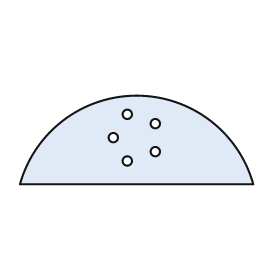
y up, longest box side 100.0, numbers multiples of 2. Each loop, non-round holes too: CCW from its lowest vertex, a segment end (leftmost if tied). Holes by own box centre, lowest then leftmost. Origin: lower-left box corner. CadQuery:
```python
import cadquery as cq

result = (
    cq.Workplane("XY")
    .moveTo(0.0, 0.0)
    .lineTo(100.0, 0.0)
    .threePointArc((50.0, 38.0), (0.0, 0.0))
    .close()
    .moveTo(46.0, 10.0)
    .circle(2.0)
    .moveTo(58.0, 14.0)
    .circle(2.0)
    .moveTo(40.0, 20.0)
    .circle(2.0)
    .moveTo(58.0, 26.0)
    .circle(2.0)
    .moveTo(46.0, 30.0)
    .circle(2.0)
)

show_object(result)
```